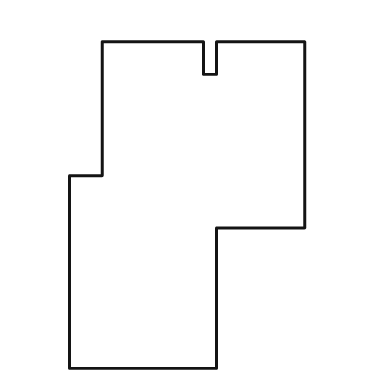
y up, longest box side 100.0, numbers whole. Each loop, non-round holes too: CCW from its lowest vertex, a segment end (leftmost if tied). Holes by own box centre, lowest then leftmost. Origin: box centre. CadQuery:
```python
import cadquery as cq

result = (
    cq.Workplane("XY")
    .moveTo(-36.0, -50.0)
    .lineTo(9.0, -50.0)
    .lineTo(9.0, -7.0)
    .lineTo(36.0, -7.0)
    .lineTo(36.0, 50.0)
    .lineTo(9.0, 50.0)
    .lineTo(9.0, 40.0)
    .lineTo(5.0, 40.0)
    .lineTo(5.0, 50.0)
    .lineTo(-26.0, 50.0)
    .lineTo(-26.0, 9.0)
    .lineTo(-36.0, 9.0)
    .close()
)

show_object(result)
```